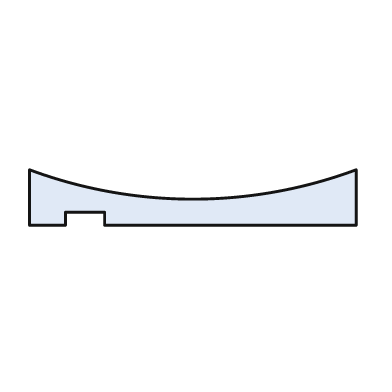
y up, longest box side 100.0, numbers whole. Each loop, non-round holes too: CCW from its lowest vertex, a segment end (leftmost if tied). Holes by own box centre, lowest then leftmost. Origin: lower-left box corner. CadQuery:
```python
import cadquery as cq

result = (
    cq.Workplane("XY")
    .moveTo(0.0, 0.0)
    .lineTo(11.0, 0.0)
    .lineTo(11.0, 4.0)
    .lineTo(23.0, 4.0)
    .lineTo(23.0, 0.0)
    .lineTo(100.0, 0.0)
    .lineTo(100.0, 17.0)
    .threePointArc((50.0, 8.0), (0.0, 17.0))
    .close()
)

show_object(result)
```